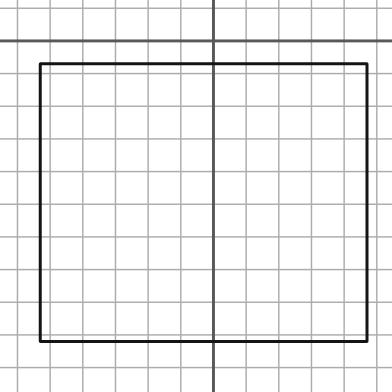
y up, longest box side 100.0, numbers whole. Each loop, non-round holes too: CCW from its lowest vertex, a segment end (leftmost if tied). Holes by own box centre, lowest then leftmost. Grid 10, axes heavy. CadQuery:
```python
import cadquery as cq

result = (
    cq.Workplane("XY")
    .moveTo(-53.0, -92.0)
    .lineTo(47.0, -92.0)
    .lineTo(47.0, -7.0)
    .lineTo(-53.0, -7.0)
    .close()
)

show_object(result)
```